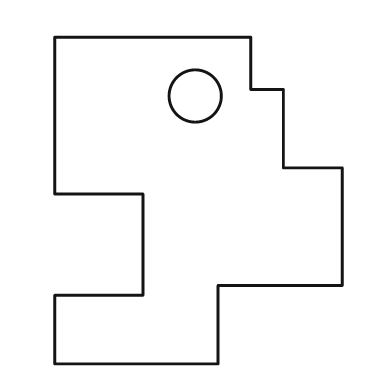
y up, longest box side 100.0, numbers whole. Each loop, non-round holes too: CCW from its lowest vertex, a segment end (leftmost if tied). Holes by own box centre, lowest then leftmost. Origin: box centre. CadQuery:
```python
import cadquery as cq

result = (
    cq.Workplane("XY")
    .moveTo(-44.0, -50.0)
    .lineTo(6.0, -50.0)
    .lineTo(6.0, -26.0)
    .lineTo(44.0, -26.0)
    .lineTo(44.0, 10.0)
    .lineTo(26.0, 10.0)
    .lineTo(26.0, 34.0)
    .lineTo(16.0, 34.0)
    .lineTo(16.0, 50.0)
    .lineTo(-44.0, 50.0)
    .lineTo(-44.0, 2.0)
    .lineTo(-17.0, 2.0)
    .lineTo(-17.0, -29.0)
    .lineTo(-44.0, -29.0)
    .close()
    .moveTo(-1.0, 32.0)
    .circle(8.0)
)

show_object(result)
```